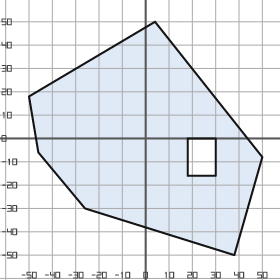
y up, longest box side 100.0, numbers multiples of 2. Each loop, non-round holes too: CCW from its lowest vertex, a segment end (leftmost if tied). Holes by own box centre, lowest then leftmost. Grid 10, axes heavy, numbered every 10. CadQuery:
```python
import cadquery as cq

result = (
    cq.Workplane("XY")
    .moveTo(38.0, -50.0)
    .lineTo(50.0, -8.0)
    .lineTo(4.0, 50.0)
    .lineTo(-50.0, 18.0)
    .lineTo(-46.0, -6.0)
    .lineTo(-26.0, -30.0)
    .close()
    .moveTo(18.0, -16.0)
    .lineTo(30.0, -16.0)
    .lineTo(30.0, 0.0)
    .lineTo(18.0, 0.0)
    .close()
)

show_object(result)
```